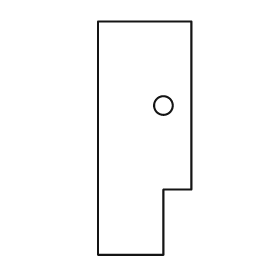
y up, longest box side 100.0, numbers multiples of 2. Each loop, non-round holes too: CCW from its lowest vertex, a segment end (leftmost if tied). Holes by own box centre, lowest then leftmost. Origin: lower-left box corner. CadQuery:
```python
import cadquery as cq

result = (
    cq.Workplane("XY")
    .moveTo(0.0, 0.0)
    .lineTo(28.0, 0.0)
    .lineTo(28.0, 28.0)
    .lineTo(40.0, 28.0)
    .lineTo(40.0, 100.0)
    .lineTo(0.0, 100.0)
    .close()
    .moveTo(28.0, 64.0)
    .circle(4.0)
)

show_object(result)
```